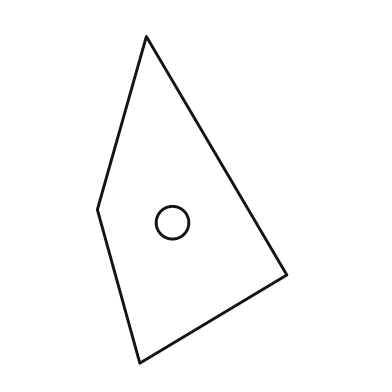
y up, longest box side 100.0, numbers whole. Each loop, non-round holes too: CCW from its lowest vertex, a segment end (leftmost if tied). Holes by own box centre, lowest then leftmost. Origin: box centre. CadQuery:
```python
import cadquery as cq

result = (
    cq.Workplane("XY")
    .moveTo(-16.0, -50.0)
    .lineTo(29.0, -23.0)
    .lineTo(-14.0, 50.0)
    .lineTo(-29.0, -3.0)
    .close()
    .moveTo(-6.0, -7.0)
    .circle(5.0)
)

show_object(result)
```